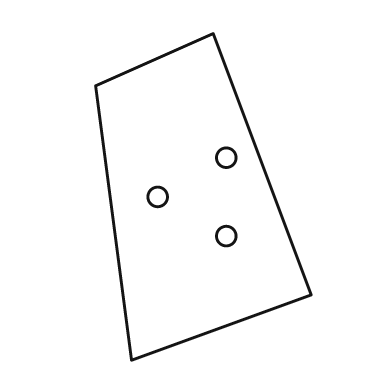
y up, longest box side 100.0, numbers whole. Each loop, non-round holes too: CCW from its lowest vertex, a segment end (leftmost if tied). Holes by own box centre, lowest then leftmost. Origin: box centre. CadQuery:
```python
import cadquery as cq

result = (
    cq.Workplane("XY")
    .moveTo(-22.0, -50.0)
    .lineTo(33.0, -30.0)
    .lineTo(3.0, 50.0)
    .lineTo(-33.0, 34.0)
    .close()
    .moveTo(7.0, -12.0)
    .circle(3.0)
    .moveTo(-14.0, 0.0)
    .circle(3.0)
    .moveTo(7.0, 12.0)
    .circle(3.0)
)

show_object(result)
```